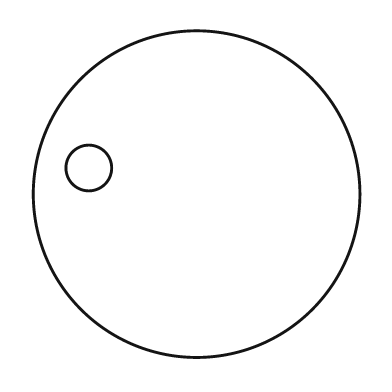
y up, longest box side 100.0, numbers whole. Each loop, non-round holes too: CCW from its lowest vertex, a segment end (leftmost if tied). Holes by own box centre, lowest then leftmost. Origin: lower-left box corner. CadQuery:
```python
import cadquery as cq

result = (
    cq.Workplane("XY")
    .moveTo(50.0, 50.0)
    .circle(50.0)
    .moveTo(17.0, 58.0)
    .circle(7.0)
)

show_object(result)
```